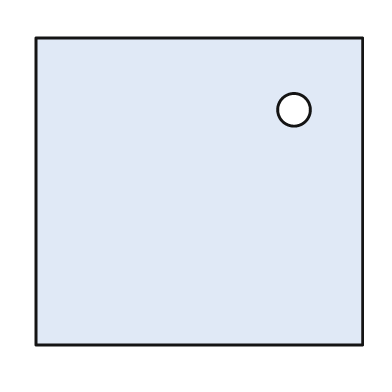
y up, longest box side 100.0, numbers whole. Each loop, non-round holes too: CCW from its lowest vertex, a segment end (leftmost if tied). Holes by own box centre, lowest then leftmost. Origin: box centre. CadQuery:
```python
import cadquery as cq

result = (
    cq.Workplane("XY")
    .moveTo(-50.0, -47.0)
    .lineTo(50.0, -47.0)
    .lineTo(50.0, 47.0)
    .lineTo(-50.0, 47.0)
    .close()
    .moveTo(29.0, 25.0)
    .circle(5.0)
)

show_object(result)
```